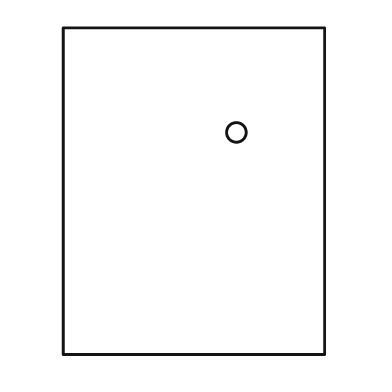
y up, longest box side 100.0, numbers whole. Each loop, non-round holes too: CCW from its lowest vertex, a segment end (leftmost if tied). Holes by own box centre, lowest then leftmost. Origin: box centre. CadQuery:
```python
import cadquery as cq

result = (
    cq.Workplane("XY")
    .moveTo(-40.0, -50.0)
    .lineTo(40.0, -50.0)
    .lineTo(40.0, 50.0)
    .lineTo(-40.0, 50.0)
    .close()
    .moveTo(13.0, 18.0)
    .circle(3.0)
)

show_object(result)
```